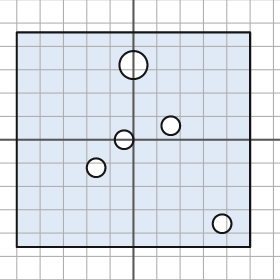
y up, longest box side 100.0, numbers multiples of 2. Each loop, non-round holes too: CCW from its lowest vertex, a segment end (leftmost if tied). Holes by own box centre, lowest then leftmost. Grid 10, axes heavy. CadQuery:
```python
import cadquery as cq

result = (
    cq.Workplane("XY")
    .moveTo(-50.0, -46.0)
    .lineTo(50.0, -46.0)
    .lineTo(50.0, 46.0)
    .lineTo(-50.0, 46.0)
    .close()
    .moveTo(38.0, -36.0)
    .circle(4.0)
    .moveTo(-16.0, -12.0)
    .circle(4.0)
    .moveTo(-4.0, 0.0)
    .circle(4.0)
    .moveTo(16.0, 6.0)
    .circle(4.0)
    .moveTo(0.0, 32.0)
    .circle(6.0)
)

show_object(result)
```